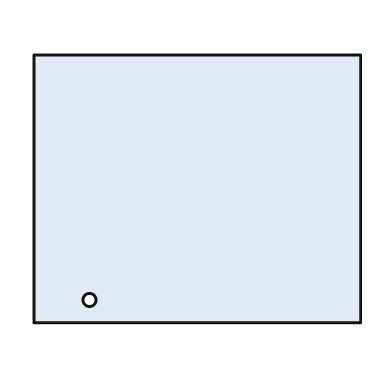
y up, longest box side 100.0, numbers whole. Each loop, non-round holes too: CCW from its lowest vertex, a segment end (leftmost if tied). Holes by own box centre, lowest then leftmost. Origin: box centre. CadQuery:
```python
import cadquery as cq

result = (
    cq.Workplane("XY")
    .moveTo(-50.0, -41.0)
    .lineTo(50.0, -41.0)
    .lineTo(50.0, 41.0)
    .lineTo(-50.0, 41.0)
    .close()
    .moveTo(-33.0, -34.0)
    .circle(2.0)
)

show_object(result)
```